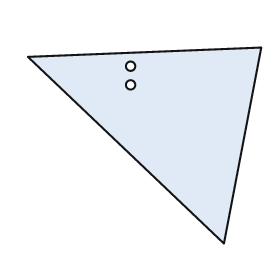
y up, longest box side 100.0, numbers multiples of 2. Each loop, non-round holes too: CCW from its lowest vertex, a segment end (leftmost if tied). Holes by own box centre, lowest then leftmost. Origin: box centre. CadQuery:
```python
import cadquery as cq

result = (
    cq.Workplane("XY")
    .moveTo(34.0, -42.0)
    .lineTo(50.0, 42.0)
    .lineTo(-50.0, 38.0)
    .close()
    .moveTo(-6.0, 26.0)
    .circle(2.0)
    .moveTo(-6.0, 34.0)
    .circle(2.0)
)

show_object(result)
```